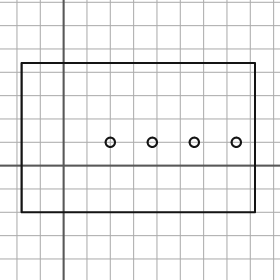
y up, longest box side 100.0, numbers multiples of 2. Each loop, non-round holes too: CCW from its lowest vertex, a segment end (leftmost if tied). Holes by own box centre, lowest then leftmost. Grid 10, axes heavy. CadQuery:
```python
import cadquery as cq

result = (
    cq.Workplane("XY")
    .moveTo(-18.0, -20.0)
    .lineTo(82.0, -20.0)
    .lineTo(82.0, 44.0)
    .lineTo(-18.0, 44.0)
    .close()
    .moveTo(20.0, 10.0)
    .circle(2.0)
    .moveTo(38.0, 10.0)
    .circle(2.0)
    .moveTo(56.0, 10.0)
    .circle(2.0)
    .moveTo(74.0, 10.0)
    .circle(2.0)
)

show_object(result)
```